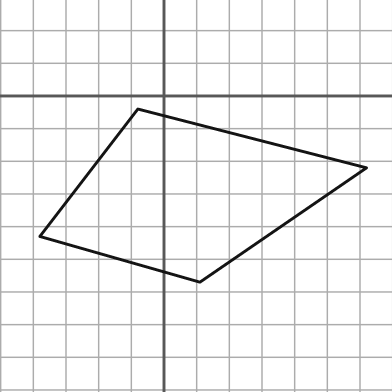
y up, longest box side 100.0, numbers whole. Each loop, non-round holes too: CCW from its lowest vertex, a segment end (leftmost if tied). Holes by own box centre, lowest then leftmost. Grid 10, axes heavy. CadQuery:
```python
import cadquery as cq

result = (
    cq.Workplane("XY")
    .moveTo(11.0, -57.0)
    .lineTo(62.0, -22.0)
    .lineTo(-8.0, -4.0)
    .lineTo(-38.0, -43.0)
    .close()
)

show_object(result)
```